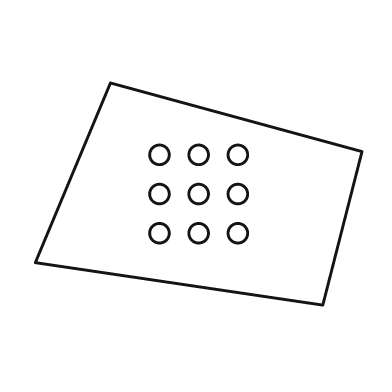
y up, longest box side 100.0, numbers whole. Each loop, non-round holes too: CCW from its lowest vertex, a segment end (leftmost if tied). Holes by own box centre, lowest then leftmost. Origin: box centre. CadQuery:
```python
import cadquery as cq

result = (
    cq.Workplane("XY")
    .moveTo(38.0, -34.0)
    .lineTo(50.0, 13.0)
    .lineTo(-27.0, 34.0)
    .lineTo(-50.0, -21.0)
    .close()
    .moveTo(-12.0, -12.0)
    .circle(3.0)
    .moveTo(0.0, -12.0)
    .circle(3.0)
    .moveTo(12.0, -12.0)
    .circle(3.0)
    .moveTo(-12.0, 0.0)
    .circle(3.0)
    .moveTo(0.0, 0.0)
    .circle(3.0)
    .moveTo(12.0, 0.0)
    .circle(3.0)
    .moveTo(-12.0, 12.0)
    .circle(3.0)
    .moveTo(0.0, 12.0)
    .circle(3.0)
    .moveTo(12.0, 12.0)
    .circle(3.0)
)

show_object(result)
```